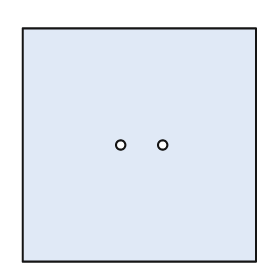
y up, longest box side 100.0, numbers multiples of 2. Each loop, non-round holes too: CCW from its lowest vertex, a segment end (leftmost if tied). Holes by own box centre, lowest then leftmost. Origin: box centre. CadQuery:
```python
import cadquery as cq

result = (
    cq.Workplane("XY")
    .moveTo(-50.0, -50.0)
    .lineTo(50.0, -50.0)
    .lineTo(50.0, 50.0)
    .lineTo(-50.0, 50.0)
    .close()
    .moveTo(-8.0, 0.0)
    .circle(2.0)
    .moveTo(10.0, 0.0)
    .circle(2.0)
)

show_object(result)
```